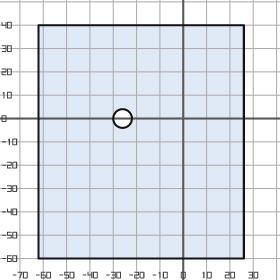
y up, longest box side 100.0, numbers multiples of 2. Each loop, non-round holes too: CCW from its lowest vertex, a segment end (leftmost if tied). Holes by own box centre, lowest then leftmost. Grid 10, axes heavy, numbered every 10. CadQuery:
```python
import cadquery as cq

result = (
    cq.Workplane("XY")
    .moveTo(-62.0, -60.0)
    .lineTo(26.0, -60.0)
    .lineTo(26.0, 40.0)
    .lineTo(-62.0, 40.0)
    .close()
    .moveTo(-26.0, 0.0)
    .circle(4.0)
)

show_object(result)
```